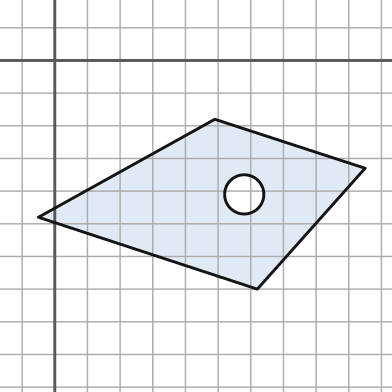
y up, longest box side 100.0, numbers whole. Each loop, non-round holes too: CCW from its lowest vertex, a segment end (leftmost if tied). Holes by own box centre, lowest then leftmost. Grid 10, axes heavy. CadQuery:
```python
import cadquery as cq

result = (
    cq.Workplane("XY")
    .moveTo(62.0, -70.0)
    .lineTo(95.0, -33.0)
    .lineTo(49.0, -18.0)
    .lineTo(-5.0, -48.0)
    .close()
    .moveTo(58.0, -41.0)
    .circle(6.0)
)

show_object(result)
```